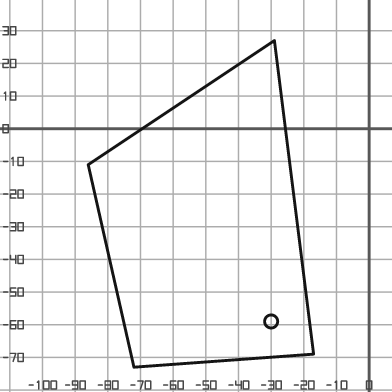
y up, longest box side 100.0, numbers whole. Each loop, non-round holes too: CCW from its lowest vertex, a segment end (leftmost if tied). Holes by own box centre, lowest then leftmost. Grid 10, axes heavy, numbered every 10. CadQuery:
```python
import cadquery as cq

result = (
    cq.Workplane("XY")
    .moveTo(-72.0, -73.0)
    .lineTo(-17.0, -69.0)
    .lineTo(-29.0, 27.0)
    .lineTo(-86.0, -11.0)
    .close()
    .moveTo(-30.0, -59.0)
    .circle(2.0)
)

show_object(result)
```